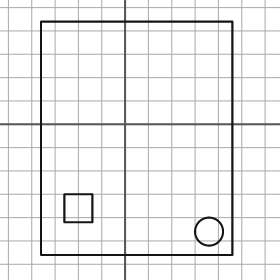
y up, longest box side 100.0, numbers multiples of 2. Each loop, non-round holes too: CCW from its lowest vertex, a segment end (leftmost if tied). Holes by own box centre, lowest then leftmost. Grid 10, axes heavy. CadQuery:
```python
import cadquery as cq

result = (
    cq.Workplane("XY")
    .moveTo(-36.0, -56.0)
    .lineTo(46.0, -56.0)
    .lineTo(46.0, 44.0)
    .lineTo(-36.0, 44.0)
    .close()
    .moveTo(36.0, -46.0)
    .circle(6.0)
    .moveTo(-26.0, -42.0)
    .lineTo(-14.0, -42.0)
    .lineTo(-14.0, -30.0)
    .lineTo(-26.0, -30.0)
    .close()
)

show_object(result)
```